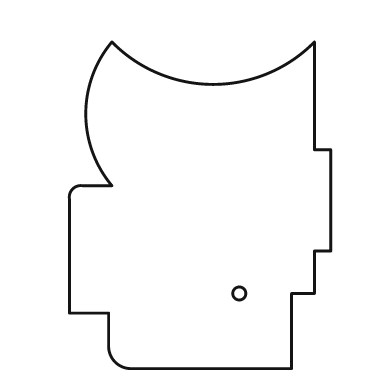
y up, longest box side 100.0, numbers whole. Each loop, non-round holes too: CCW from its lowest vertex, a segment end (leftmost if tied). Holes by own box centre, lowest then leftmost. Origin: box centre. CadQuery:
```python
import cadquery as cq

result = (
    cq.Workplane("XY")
    .moveTo(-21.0, -50.0)
    .lineTo(28.0, -50.0)
    .lineTo(28.0, -27.0)
    .lineTo(35.0, -27.0)
    .lineTo(35.0, -14.0)
    .lineTo(40.0, -14.0)
    .lineTo(40.0, 17.0)
    .lineTo(35.0, 17.0)
    .lineTo(35.0, 50.0)
    .threePointArc((4.0, 37.0), (-27.0, 50.0))
    .threePointArc((-35.0, 28.0), (-27.0, 6.0))
    .lineTo(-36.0, 6.0)
    .threePointArc((-39.0, 5.0), (-40.0, 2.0))
    .lineTo(-40.0, -33.0)
    .lineTo(-28.0, -33.0)
    .lineTo(-28.0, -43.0)
    .threePointArc((-26.0, -48.0), (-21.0, -50.0))
    .close()
    .moveTo(12.0, -27.0)
    .circle(2.0)
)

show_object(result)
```